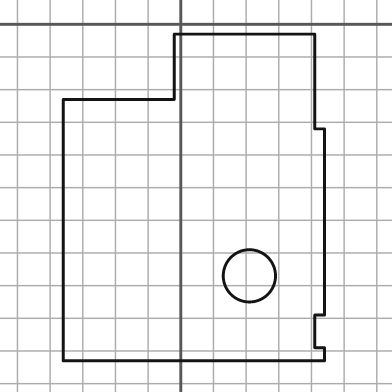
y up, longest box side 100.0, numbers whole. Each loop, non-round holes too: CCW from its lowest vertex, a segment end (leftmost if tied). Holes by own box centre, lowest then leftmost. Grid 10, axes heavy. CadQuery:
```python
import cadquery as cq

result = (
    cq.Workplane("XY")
    .moveTo(-36.0, -103.0)
    .lineTo(44.0, -103.0)
    .lineTo(44.0, -99.0)
    .lineTo(41.0, -99.0)
    .lineTo(41.0, -89.0)
    .lineTo(44.0, -89.0)
    .lineTo(44.0, -32.0)
    .lineTo(41.0, -32.0)
    .lineTo(41.0, -3.0)
    .lineTo(-2.0, -3.0)
    .lineTo(-2.0, -23.0)
    .lineTo(-36.0, -23.0)
    .close()
    .moveTo(21.0, -77.0)
    .circle(8.0)
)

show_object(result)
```